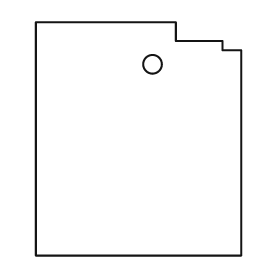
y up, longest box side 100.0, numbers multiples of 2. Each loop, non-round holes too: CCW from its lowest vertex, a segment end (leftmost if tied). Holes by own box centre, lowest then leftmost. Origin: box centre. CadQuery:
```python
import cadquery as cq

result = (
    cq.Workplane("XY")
    .moveTo(-44.0, -50.0)
    .lineTo(44.0, -50.0)
    .lineTo(44.0, 38.0)
    .lineTo(36.0, 38.0)
    .lineTo(36.0, 42.0)
    .lineTo(16.0, 42.0)
    .lineTo(16.0, 50.0)
    .lineTo(-44.0, 50.0)
    .close()
    .moveTo(6.0, 32.0)
    .circle(4.0)
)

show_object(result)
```